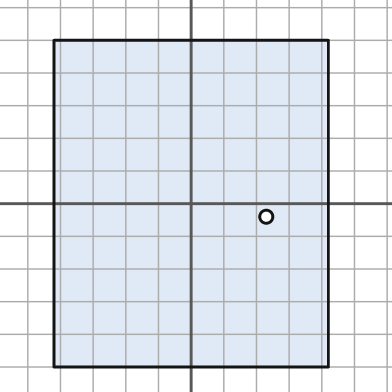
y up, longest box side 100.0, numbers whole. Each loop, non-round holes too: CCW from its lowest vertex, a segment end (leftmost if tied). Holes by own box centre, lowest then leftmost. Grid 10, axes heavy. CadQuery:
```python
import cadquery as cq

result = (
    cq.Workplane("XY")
    .moveTo(-42.0, -50.0)
    .lineTo(42.0, -50.0)
    .lineTo(42.0, 50.0)
    .lineTo(-42.0, 50.0)
    .close()
    .moveTo(23.0, -4.0)
    .circle(2.0)
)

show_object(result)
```